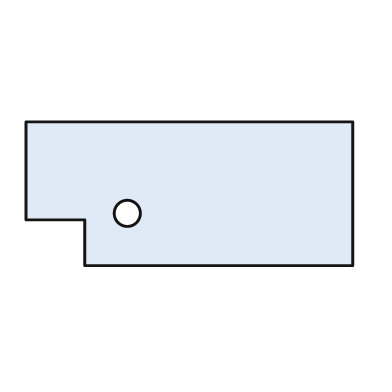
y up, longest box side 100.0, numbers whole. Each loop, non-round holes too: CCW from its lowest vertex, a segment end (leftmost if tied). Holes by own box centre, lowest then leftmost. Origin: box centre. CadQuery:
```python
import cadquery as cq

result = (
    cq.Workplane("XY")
    .moveTo(-32.0, -22.0)
    .lineTo(50.0, -22.0)
    .lineTo(50.0, 22.0)
    .lineTo(-50.0, 22.0)
    .lineTo(-50.0, -8.0)
    .lineTo(-32.0, -8.0)
    .close()
    .moveTo(-19.0, -6.0)
    .circle(4.0)
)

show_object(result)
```